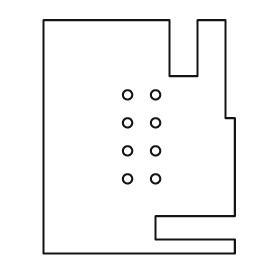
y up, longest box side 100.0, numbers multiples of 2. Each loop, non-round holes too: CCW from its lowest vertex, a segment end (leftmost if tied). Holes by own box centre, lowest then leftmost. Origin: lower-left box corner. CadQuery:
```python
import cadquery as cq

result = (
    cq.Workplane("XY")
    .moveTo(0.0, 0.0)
    .lineTo(82.0, 0.0)
    .lineTo(82.0, 6.0)
    .lineTo(48.0, 6.0)
    .lineTo(48.0, 16.0)
    .lineTo(82.0, 16.0)
    .lineTo(82.0, 58.0)
    .lineTo(78.0, 58.0)
    .lineTo(78.0, 100.0)
    .lineTo(66.0, 100.0)
    .lineTo(66.0, 76.0)
    .lineTo(54.0, 76.0)
    .lineTo(54.0, 100.0)
    .lineTo(0.0, 100.0)
    .close()
    .moveTo(36.0, 32.0)
    .circle(2.0)
    .moveTo(48.0, 32.0)
    .circle(2.0)
    .moveTo(36.0, 44.0)
    .circle(2.0)
    .moveTo(48.0, 44.0)
    .circle(2.0)
    .moveTo(36.0, 56.0)
    .circle(2.0)
    .moveTo(48.0, 56.0)
    .circle(2.0)
    .moveTo(36.0, 68.0)
    .circle(2.0)
    .moveTo(48.0, 68.0)
    .circle(2.0)
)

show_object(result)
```